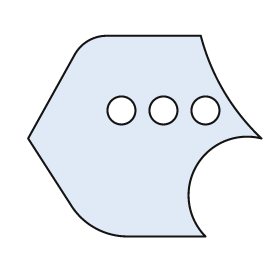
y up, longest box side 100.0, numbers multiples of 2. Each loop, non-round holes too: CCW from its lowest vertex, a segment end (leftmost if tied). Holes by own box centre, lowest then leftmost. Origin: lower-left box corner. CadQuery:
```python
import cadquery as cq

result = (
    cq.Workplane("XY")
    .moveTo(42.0, 0.0)
    .lineTo(76.0, 0.0)
    .threePointArc((72.0, 30.0), (100.0, 42.0))
    .threePointArc((84.0, 62.0), (74.0, 86.0))
    .lineTo(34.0, 86.0)
    .threePointArc((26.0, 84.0), (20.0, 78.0))
    .lineTo(0.0, 42.0)
    .lineTo(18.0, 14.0)
    .threePointArc((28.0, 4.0), (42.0, 0.0))
    .close()
    .moveTo(40.0, 54.0)
    .circle(6.0)
    .moveTo(58.0, 54.0)
    .circle(6.0)
    .moveTo(76.0, 54.0)
    .circle(6.0)
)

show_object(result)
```